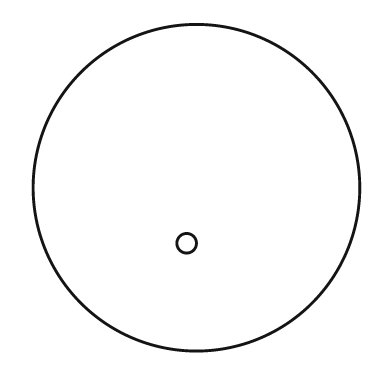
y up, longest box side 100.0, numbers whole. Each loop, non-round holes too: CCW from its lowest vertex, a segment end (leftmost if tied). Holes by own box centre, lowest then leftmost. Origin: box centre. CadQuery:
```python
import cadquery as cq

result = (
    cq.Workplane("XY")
    .moveTo(0.0, 0.0)
    .circle(50.0)
    .moveTo(-3.0, -17.0)
    .circle(3.0)
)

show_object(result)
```